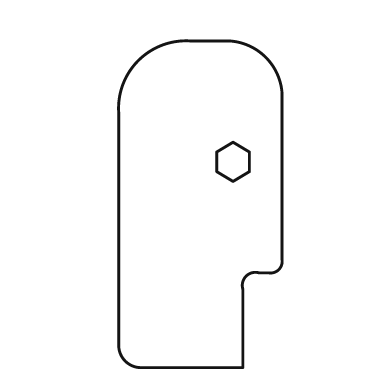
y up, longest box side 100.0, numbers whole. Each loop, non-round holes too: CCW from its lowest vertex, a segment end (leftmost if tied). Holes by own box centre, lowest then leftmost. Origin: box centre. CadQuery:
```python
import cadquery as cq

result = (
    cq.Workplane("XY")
    .moveTo(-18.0, -50.0)
    .lineTo(13.0, -50.0)
    .lineTo(13.0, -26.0)
    .threePointArc((14.0, -22.0), (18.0, -21.0))
    .lineTo(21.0, -21.0)
    .threePointArc((24.0, -20.0), (25.0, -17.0))
    .lineTo(25.0, 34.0)
    .threePointArc((20.0, 45.0), (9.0, 50.0))
    .lineTo(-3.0, 50.0)
    .threePointArc((-19.0, 44.0), (-25.0, 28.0))
    .lineTo(-25.0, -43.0)
    .threePointArc((-23.0, -48.0), (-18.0, -50.0))
    .close()
    .moveTo(10.0, 7.0)
    .lineTo(15.0, 10.0)
    .lineTo(15.0, 16.0)
    .lineTo(10.0, 19.0)
    .lineTo(5.0, 16.0)
    .lineTo(5.0, 10.0)
    .close()
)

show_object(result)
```